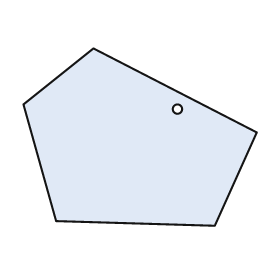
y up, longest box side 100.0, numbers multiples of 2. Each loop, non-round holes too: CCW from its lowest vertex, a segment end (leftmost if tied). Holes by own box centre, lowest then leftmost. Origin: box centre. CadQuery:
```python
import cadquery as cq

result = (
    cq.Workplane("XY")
    .moveTo(32.0, -38.0)
    .lineTo(50.0, 2.0)
    .lineTo(-20.0, 38.0)
    .lineTo(-50.0, 14.0)
    .lineTo(-36.0, -36.0)
    .close()
    .moveTo(16.0, 12.0)
    .circle(2.0)
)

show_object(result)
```